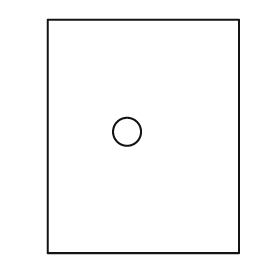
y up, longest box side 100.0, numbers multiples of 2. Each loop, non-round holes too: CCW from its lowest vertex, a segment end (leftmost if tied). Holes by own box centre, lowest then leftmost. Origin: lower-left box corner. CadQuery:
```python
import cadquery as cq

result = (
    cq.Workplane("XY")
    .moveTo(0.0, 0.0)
    .lineTo(82.0, 0.0)
    .lineTo(82.0, 100.0)
    .lineTo(0.0, 100.0)
    .close()
    .moveTo(34.0, 52.0)
    .circle(6.0)
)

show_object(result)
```